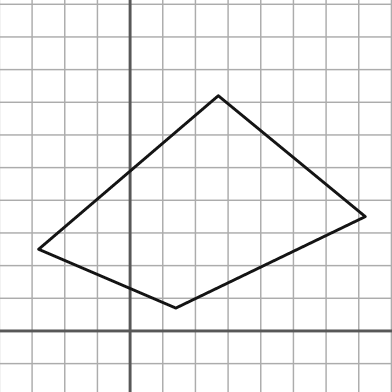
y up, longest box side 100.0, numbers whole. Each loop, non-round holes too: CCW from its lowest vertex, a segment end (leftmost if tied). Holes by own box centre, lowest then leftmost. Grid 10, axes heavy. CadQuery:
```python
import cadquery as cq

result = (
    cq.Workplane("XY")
    .moveTo(14.0, 7.0)
    .lineTo(72.0, 35.0)
    .lineTo(27.0, 72.0)
    .lineTo(-28.0, 25.0)
    .close()
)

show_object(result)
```